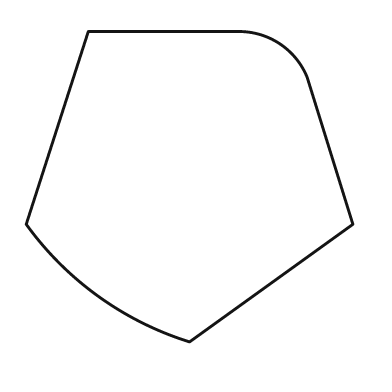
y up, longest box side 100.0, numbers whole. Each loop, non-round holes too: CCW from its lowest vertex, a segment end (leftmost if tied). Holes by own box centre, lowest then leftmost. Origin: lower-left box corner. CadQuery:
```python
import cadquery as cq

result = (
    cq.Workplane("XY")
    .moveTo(50.0, 0.0)
    .lineTo(100.0, 36.0)
    .lineTo(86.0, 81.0)
    .threePointArc((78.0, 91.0), (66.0, 95.0))
    .lineTo(19.0, 95.0)
    .lineTo(0.0, 36.0)
    .threePointArc((22.0, 14.0), (50.0, 0.0))
    .close()
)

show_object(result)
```